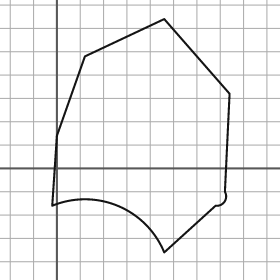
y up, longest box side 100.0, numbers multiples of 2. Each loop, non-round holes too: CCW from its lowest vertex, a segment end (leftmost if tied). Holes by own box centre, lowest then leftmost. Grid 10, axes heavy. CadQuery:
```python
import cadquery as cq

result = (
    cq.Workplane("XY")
    .moveTo(46.0, -36.0)
    .lineTo(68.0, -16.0)
    .threePointArc((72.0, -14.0), (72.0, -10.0))
    .lineTo(74.0, 32.0)
    .lineTo(46.0, 64.0)
    .lineTo(12.0, 48.0)
    .lineTo(0.0, 14.0)
    .lineTo(-2.0, -16.0)
    .threePointArc((26.0, -16.0), (46.0, -36.0))
    .close()
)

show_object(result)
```